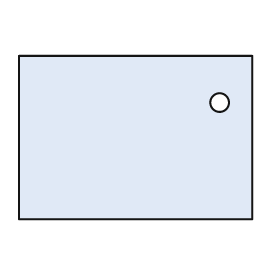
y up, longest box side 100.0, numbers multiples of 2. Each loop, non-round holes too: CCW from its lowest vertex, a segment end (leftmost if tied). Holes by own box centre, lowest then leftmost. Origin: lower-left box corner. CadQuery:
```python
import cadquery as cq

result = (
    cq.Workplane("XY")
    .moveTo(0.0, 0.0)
    .lineTo(100.0, 0.0)
    .lineTo(100.0, 70.0)
    .lineTo(0.0, 70.0)
    .close()
    .moveTo(86.0, 50.0)
    .circle(4.0)
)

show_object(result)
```